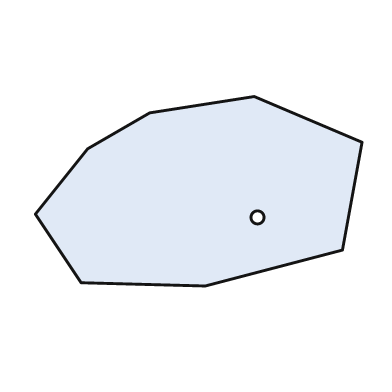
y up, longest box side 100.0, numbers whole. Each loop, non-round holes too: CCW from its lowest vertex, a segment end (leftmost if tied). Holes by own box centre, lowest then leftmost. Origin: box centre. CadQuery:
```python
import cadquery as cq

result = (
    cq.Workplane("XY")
    .moveTo(2.0, -29.0)
    .lineTo(44.0, -18.0)
    .lineTo(50.0, 15.0)
    .lineTo(17.0, 29.0)
    .lineTo(-15.0, 24.0)
    .lineTo(-34.0, 13.0)
    .lineTo(-50.0, -7.0)
    .lineTo(-36.0, -28.0)
    .close()
    .moveTo(18.0, -8.0)
    .circle(2.0)
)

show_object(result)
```